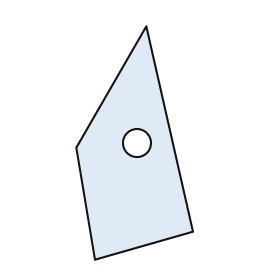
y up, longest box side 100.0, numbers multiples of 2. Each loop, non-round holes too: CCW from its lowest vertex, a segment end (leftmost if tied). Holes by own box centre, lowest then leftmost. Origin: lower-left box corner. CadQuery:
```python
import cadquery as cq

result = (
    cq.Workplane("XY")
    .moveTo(8.0, 0.0)
    .lineTo(50.0, 12.0)
    .lineTo(30.0, 100.0)
    .lineTo(0.0, 48.0)
    .close()
    .moveTo(26.0, 50.0)
    .circle(6.0)
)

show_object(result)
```